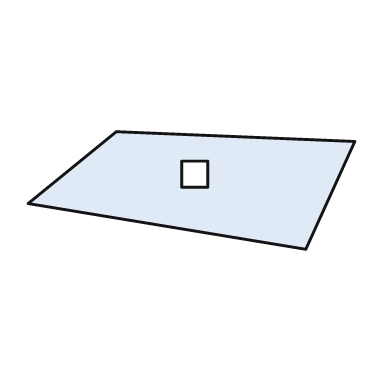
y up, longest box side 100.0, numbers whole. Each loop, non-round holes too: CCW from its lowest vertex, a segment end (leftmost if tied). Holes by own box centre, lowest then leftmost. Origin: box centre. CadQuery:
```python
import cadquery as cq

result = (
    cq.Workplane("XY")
    .moveTo(35.0, -18.0)
    .lineTo(50.0, 15.0)
    .lineTo(-23.0, 18.0)
    .lineTo(-50.0, -4.0)
    .close()
    .moveTo(-3.0, 1.0)
    .lineTo(5.0, 1.0)
    .lineTo(5.0, 9.0)
    .lineTo(-3.0, 9.0)
    .close()
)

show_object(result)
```